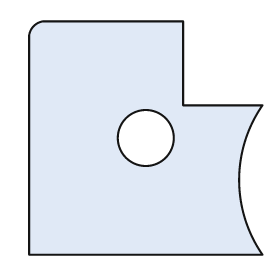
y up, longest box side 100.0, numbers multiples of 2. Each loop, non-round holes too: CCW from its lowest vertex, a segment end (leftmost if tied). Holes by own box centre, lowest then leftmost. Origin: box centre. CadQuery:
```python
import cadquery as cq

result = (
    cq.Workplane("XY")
    .moveTo(-50.0, -50.0)
    .lineTo(50.0, -50.0)
    .threePointArc((40.0, -18.0), (50.0, 14.0))
    .lineTo(16.0, 14.0)
    .lineTo(16.0, 50.0)
    .lineTo(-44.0, 50.0)
    .threePointArc((-48.0, 48.0), (-50.0, 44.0))
    .close()
    .moveTo(0.0, 0.0)
    .circle(12.0)
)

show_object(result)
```